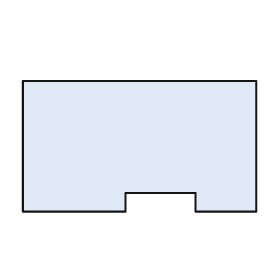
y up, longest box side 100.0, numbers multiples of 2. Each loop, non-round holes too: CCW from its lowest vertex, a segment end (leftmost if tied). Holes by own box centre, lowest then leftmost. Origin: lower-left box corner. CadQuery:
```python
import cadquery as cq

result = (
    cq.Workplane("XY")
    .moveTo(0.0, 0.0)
    .lineTo(44.0, 0.0)
    .lineTo(44.0, 8.0)
    .lineTo(74.0, 8.0)
    .lineTo(74.0, 0.0)
    .lineTo(100.0, 0.0)
    .lineTo(100.0, 56.0)
    .lineTo(0.0, 56.0)
    .close()
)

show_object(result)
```